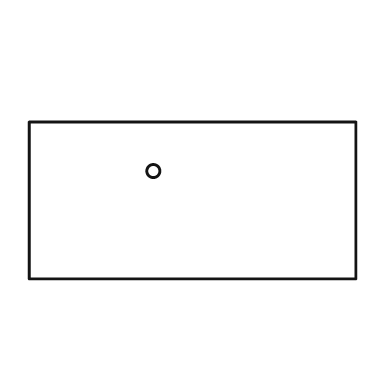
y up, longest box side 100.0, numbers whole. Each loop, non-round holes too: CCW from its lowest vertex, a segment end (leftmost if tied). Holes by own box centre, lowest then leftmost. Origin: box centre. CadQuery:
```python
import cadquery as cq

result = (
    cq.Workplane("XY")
    .moveTo(-50.0, -24.0)
    .lineTo(50.0, -24.0)
    .lineTo(50.0, 24.0)
    .lineTo(-50.0, 24.0)
    .close()
    .moveTo(-12.0, 9.0)
    .circle(2.0)
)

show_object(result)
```